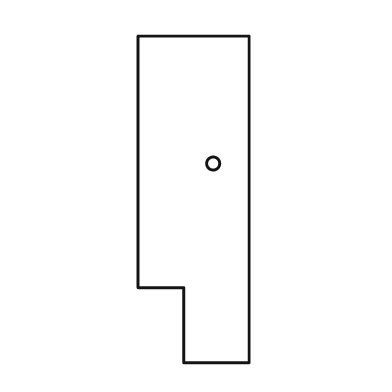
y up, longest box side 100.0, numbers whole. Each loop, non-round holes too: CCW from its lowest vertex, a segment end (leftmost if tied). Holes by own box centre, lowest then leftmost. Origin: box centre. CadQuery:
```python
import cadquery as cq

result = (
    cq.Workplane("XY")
    .moveTo(-3.0, -50.0)
    .lineTo(17.0, -50.0)
    .lineTo(17.0, 50.0)
    .lineTo(-17.0, 50.0)
    .lineTo(-17.0, -27.0)
    .lineTo(-3.0, -27.0)
    .close()
    .moveTo(6.0, 11.0)
    .circle(2.0)
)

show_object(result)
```